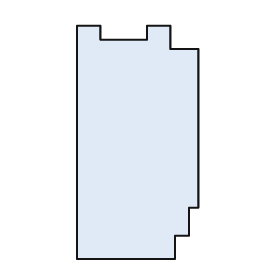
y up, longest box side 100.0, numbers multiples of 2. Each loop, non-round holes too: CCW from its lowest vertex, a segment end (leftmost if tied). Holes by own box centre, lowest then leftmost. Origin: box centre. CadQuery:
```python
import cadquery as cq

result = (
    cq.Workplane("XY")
    .moveTo(-26.0, -50.0)
    .lineTo(16.0, -50.0)
    .lineTo(16.0, -40.0)
    .lineTo(22.0, -40.0)
    .lineTo(22.0, -28.0)
    .lineTo(26.0, -28.0)
    .lineTo(26.0, 40.0)
    .lineTo(14.0, 40.0)
    .lineTo(14.0, 50.0)
    .lineTo(4.0, 50.0)
    .lineTo(4.0, 44.0)
    .lineTo(-16.0, 44.0)
    .lineTo(-16.0, 50.0)
    .lineTo(-26.0, 50.0)
    .close()
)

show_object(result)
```